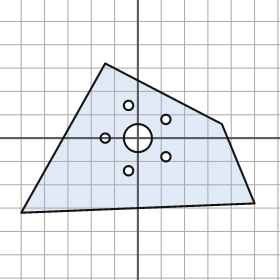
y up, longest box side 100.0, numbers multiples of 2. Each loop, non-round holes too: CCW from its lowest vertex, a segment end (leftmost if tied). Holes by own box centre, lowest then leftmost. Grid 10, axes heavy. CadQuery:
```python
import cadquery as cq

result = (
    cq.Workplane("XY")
    .moveTo(-50.0, -32.0)
    .lineTo(50.0, -28.0)
    .lineTo(36.0, 6.0)
    .lineTo(-14.0, 32.0)
    .close()
    .moveTo(-4.0, -14.0)
    .circle(2.0)
    .moveTo(12.0, -8.0)
    .circle(2.0)
    .moveTo(-14.0, 0.0)
    .circle(2.0)
    .moveTo(0.0, 0.0)
    .circle(6.0)
    .moveTo(12.0, 8.0)
    .circle(2.0)
    .moveTo(-4.0, 14.0)
    .circle(2.0)
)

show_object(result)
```